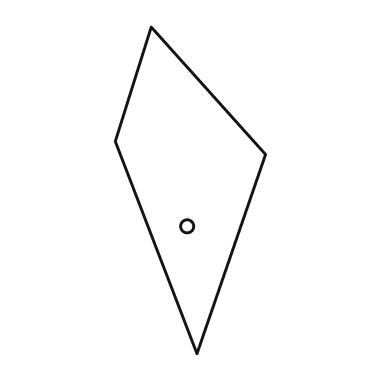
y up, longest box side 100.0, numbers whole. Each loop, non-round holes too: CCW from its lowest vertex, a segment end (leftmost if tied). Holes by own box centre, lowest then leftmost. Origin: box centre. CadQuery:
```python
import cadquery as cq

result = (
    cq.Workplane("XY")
    .moveTo(2.0, -50.0)
    .lineTo(23.0, 11.0)
    .lineTo(-12.0, 50.0)
    .lineTo(-23.0, 15.0)
    .close()
    .moveTo(-1.0, -11.0)
    .circle(2.0)
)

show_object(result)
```